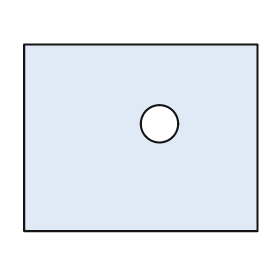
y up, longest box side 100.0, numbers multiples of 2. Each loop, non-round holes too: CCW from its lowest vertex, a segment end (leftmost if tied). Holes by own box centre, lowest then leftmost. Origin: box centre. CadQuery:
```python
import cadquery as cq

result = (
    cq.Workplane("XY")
    .moveTo(-50.0, -40.0)
    .lineTo(50.0, -40.0)
    .lineTo(50.0, 40.0)
    .lineTo(-50.0, 40.0)
    .close()
    .moveTo(8.0, 6.0)
    .circle(8.0)
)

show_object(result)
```